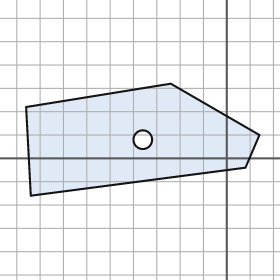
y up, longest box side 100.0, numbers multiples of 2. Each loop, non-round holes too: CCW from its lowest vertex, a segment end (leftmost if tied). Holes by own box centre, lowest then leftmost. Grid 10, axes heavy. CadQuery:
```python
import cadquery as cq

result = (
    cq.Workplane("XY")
    .moveTo(-84.0, -16.0)
    .lineTo(8.0, -4.0)
    .lineTo(14.0, 10.0)
    .lineTo(-24.0, 32.0)
    .lineTo(-86.0, 22.0)
    .close()
    .moveTo(-36.0, 8.0)
    .circle(4.0)
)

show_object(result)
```